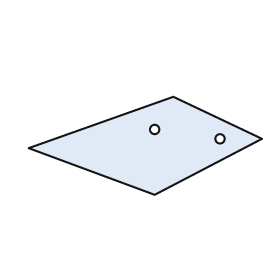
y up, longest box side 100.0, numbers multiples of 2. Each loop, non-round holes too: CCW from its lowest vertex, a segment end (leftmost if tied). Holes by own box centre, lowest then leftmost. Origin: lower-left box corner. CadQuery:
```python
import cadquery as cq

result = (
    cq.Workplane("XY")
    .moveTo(54.0, 0.0)
    .lineTo(100.0, 24.0)
    .lineTo(62.0, 42.0)
    .lineTo(0.0, 20.0)
    .close()
    .moveTo(82.0, 24.0)
    .circle(2.0)
    .moveTo(54.0, 28.0)
    .circle(2.0)
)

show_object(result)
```